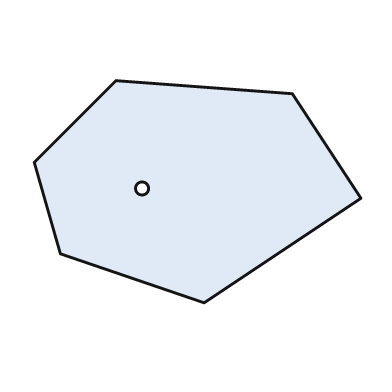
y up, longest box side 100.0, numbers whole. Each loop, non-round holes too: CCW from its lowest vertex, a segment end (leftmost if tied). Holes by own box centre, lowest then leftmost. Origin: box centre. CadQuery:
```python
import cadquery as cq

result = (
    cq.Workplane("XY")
    .moveTo(2.0, -34.0)
    .lineTo(50.0, -2.0)
    .lineTo(29.0, 30.0)
    .lineTo(-25.0, 34.0)
    .lineTo(-50.0, 9.0)
    .lineTo(-42.0, -19.0)
    .close()
    .moveTo(-17.0, 1.0)
    .circle(2.0)
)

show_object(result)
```